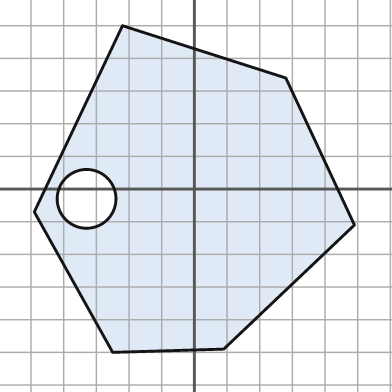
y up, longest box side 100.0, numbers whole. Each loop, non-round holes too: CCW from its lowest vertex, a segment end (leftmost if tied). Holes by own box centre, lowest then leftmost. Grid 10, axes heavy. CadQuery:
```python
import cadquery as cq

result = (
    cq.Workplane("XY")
    .moveTo(-25.0, -50.0)
    .lineTo(9.0, -49.0)
    .lineTo(49.0, -11.0)
    .lineTo(28.0, 34.0)
    .lineTo(-22.0, 50.0)
    .lineTo(-49.0, -7.0)
    .close()
    .moveTo(-33.0, -3.0)
    .circle(9.0)
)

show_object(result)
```